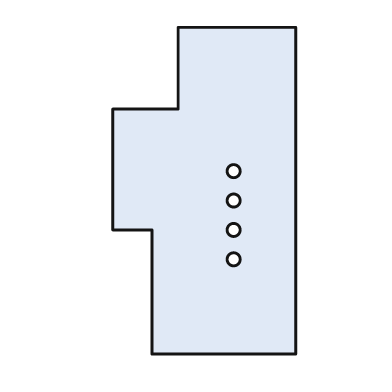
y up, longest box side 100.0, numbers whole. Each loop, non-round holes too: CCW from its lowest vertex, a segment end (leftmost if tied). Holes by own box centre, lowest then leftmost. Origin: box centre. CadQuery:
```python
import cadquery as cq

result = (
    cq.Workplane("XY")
    .moveTo(-16.0, -50.0)
    .lineTo(28.0, -50.0)
    .lineTo(28.0, 50.0)
    .lineTo(-8.0, 50.0)
    .lineTo(-8.0, 25.0)
    .lineTo(-28.0, 25.0)
    .lineTo(-28.0, -12.0)
    .lineTo(-16.0, -12.0)
    .close()
    .moveTo(9.0, -21.0)
    .circle(2.0)
    .moveTo(9.0, -12.0)
    .circle(2.0)
    .moveTo(9.0, -3.0)
    .circle(2.0)
    .moveTo(9.0, 6.0)
    .circle(2.0)
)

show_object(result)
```